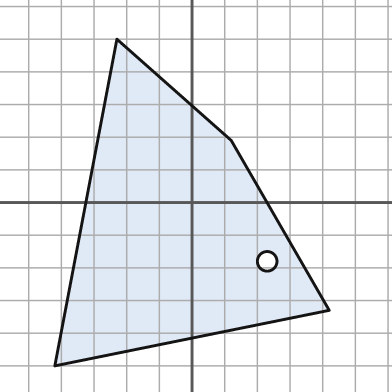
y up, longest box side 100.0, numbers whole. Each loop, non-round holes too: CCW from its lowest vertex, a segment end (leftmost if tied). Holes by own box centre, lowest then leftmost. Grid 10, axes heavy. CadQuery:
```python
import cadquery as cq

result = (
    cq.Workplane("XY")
    .moveTo(-42.0, -50.0)
    .lineTo(42.0, -33.0)
    .lineTo(12.0, 19.0)
    .lineTo(-23.0, 50.0)
    .close()
    .moveTo(23.0, -18.0)
    .circle(3.0)
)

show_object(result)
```